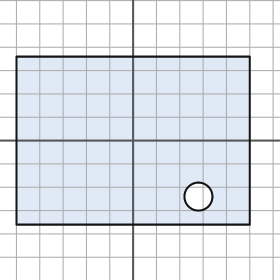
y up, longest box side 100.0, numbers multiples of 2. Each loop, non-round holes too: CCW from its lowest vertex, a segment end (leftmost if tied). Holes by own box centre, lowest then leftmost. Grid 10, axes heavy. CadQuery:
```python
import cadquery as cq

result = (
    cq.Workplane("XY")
    .moveTo(-50.0, -36.0)
    .lineTo(50.0, -36.0)
    .lineTo(50.0, 36.0)
    .lineTo(-50.0, 36.0)
    .close()
    .moveTo(28.0, -24.0)
    .circle(6.0)
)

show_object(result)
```